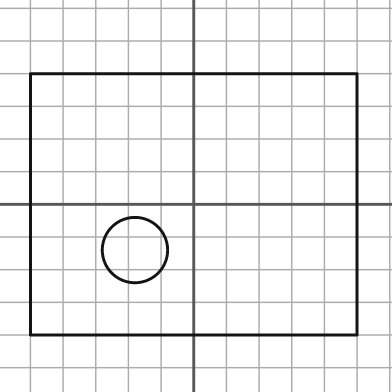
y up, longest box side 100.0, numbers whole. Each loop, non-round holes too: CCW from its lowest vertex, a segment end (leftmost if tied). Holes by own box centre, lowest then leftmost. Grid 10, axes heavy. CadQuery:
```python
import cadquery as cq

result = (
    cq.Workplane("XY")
    .moveTo(-50.0, -40.0)
    .lineTo(50.0, -40.0)
    .lineTo(50.0, 40.0)
    .lineTo(-50.0, 40.0)
    .close()
    .moveTo(-18.0, -14.0)
    .circle(10.0)
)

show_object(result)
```